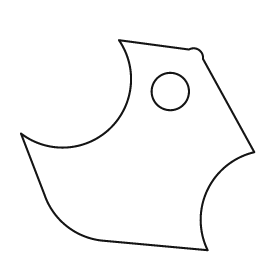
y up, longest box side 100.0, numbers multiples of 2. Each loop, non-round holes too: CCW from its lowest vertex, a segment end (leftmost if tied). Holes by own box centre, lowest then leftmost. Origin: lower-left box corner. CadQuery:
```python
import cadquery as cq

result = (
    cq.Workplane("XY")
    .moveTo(80.0, 0.0)
    .threePointArc((80.0, 26.0), (100.0, 42.0))
    .lineTo(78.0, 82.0)
    .threePointArc((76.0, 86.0), (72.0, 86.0))
    .lineTo(42.0, 90.0)
    .threePointArc((38.0, 52.0), (0.0, 50.0))
    .lineTo(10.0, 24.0)
    .threePointArc((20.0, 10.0), (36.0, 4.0))
    .close()
    .moveTo(64.0, 68.0)
    .circle(8.0)
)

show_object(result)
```